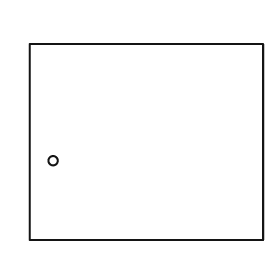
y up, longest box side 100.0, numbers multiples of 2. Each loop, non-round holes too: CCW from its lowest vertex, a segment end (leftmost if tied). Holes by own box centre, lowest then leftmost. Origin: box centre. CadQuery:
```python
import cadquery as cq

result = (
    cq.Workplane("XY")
    .moveTo(-50.0, -42.0)
    .lineTo(50.0, -42.0)
    .lineTo(50.0, 42.0)
    .lineTo(-50.0, 42.0)
    .close()
    .moveTo(-40.0, -8.0)
    .circle(2.0)
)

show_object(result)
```